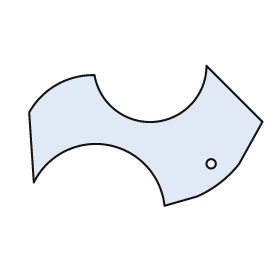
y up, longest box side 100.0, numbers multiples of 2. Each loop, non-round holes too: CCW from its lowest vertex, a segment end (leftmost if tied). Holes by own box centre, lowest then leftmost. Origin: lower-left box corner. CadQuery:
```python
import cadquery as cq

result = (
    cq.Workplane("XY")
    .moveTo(58.0, 0.0)
    .lineTo(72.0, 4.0)
    .threePointArc((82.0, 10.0), (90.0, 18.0))
    .lineTo(100.0, 36.0)
    .lineTo(76.0, 60.0)
    .threePointArc((54.0, 36.0), (28.0, 56.0))
    .threePointArc((12.0, 52.0), (0.0, 40.0))
    .lineTo(2.0, 10.0)
    .threePointArc((34.0, 26.0), (58.0, 0.0))
    .close()
    .moveTo(78.0, 18.0)
    .circle(2.0)
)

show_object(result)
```